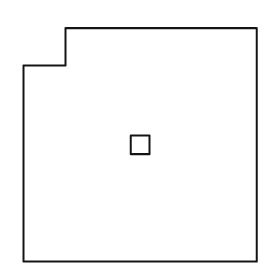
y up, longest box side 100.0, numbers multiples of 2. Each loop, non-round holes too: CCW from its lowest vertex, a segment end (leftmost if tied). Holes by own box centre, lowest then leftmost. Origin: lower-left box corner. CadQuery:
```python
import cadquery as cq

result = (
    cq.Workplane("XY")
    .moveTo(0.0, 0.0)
    .lineTo(100.0, 0.0)
    .lineTo(100.0, 100.0)
    .lineTo(18.0, 100.0)
    .lineTo(18.0, 84.0)
    .lineTo(0.0, 84.0)
    .close()
    .moveTo(46.0, 46.0)
    .lineTo(54.0, 46.0)
    .lineTo(54.0, 54.0)
    .lineTo(46.0, 54.0)
    .close()
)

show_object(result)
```